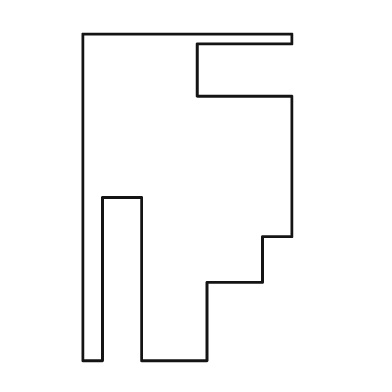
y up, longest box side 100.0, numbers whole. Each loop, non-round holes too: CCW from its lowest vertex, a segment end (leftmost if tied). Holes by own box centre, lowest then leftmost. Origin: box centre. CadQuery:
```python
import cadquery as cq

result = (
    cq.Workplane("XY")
    .moveTo(-32.0, -50.0)
    .lineTo(-26.0, -50.0)
    .lineTo(-26.0, 0.0)
    .lineTo(-14.0, 0.0)
    .lineTo(-14.0, -50.0)
    .lineTo(6.0, -50.0)
    .lineTo(6.0, -26.0)
    .lineTo(23.0, -26.0)
    .lineTo(23.0, -12.0)
    .lineTo(32.0, -12.0)
    .lineTo(32.0, 31.0)
    .lineTo(3.0, 31.0)
    .lineTo(3.0, 47.0)
    .lineTo(32.0, 47.0)
    .lineTo(32.0, 50.0)
    .lineTo(-32.0, 50.0)
    .close()
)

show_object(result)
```